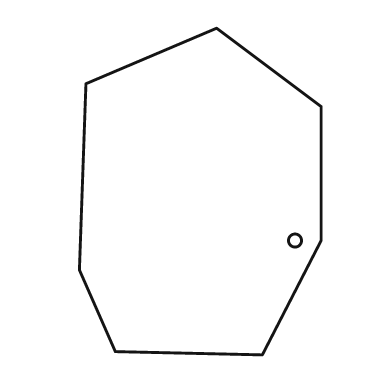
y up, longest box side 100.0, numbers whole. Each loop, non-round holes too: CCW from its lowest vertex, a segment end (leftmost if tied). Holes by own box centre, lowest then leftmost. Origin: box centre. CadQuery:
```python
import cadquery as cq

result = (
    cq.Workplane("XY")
    .moveTo(19.0, -50.0)
    .lineTo(37.0, -15.0)
    .lineTo(37.0, 26.0)
    .lineTo(5.0, 50.0)
    .lineTo(-35.0, 33.0)
    .lineTo(-37.0, -24.0)
    .lineTo(-26.0, -49.0)
    .close()
    .moveTo(29.0, -15.0)
    .circle(2.0)
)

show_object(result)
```